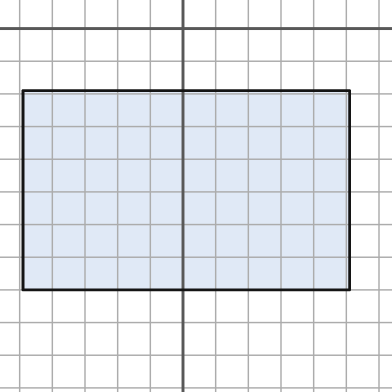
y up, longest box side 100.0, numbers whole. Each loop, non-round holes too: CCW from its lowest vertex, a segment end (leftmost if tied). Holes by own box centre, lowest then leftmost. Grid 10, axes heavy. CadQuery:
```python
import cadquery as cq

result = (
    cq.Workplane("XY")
    .moveTo(-49.0, -80.0)
    .lineTo(51.0, -80.0)
    .lineTo(51.0, -19.0)
    .lineTo(-49.0, -19.0)
    .close()
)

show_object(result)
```